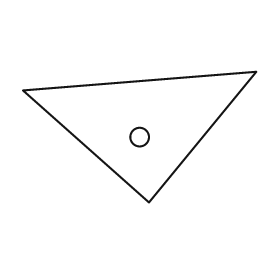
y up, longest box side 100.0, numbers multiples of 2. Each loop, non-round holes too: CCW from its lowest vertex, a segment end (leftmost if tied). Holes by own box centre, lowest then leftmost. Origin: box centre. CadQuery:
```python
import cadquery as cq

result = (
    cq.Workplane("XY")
    .moveTo(4.0, -28.0)
    .lineTo(50.0, 28.0)
    .lineTo(-50.0, 20.0)
    .close()
    .moveTo(0.0, 0.0)
    .circle(4.0)
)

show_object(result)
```